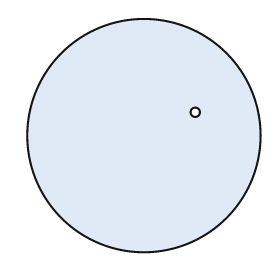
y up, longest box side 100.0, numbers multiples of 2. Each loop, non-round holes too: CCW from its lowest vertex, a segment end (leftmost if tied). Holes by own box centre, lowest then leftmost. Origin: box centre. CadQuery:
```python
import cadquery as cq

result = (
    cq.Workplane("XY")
    .moveTo(0.0, 0.0)
    .circle(50.0)
    .moveTo(22.0, 10.0)
    .circle(2.0)
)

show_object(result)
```